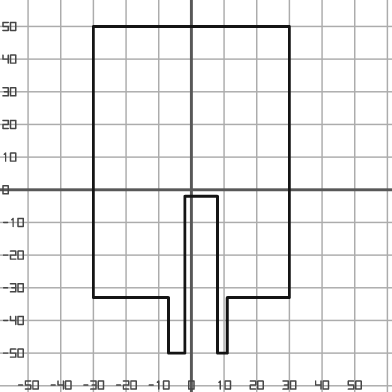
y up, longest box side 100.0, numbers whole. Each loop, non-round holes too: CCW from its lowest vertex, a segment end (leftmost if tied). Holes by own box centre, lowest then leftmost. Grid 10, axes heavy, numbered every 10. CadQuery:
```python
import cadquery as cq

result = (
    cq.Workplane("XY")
    .moveTo(-7.0, -50.0)
    .lineTo(-2.0, -50.0)
    .lineTo(-2.0, -2.0)
    .lineTo(8.0, -2.0)
    .lineTo(8.0, -50.0)
    .lineTo(11.0, -50.0)
    .lineTo(11.0, -33.0)
    .lineTo(30.0, -33.0)
    .lineTo(30.0, 50.0)
    .lineTo(-30.0, 50.0)
    .lineTo(-30.0, -33.0)
    .lineTo(-7.0, -33.0)
    .close()
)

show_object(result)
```